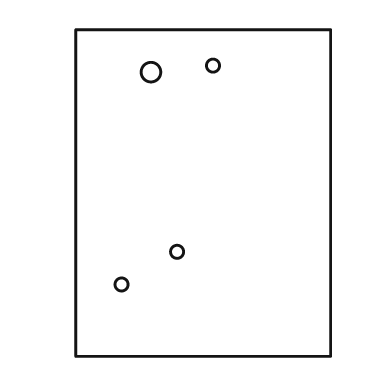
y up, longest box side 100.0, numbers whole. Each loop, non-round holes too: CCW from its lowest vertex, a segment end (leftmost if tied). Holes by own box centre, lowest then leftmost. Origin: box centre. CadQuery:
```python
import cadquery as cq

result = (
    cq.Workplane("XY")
    .moveTo(-39.0, -50.0)
    .lineTo(39.0, -50.0)
    .lineTo(39.0, 50.0)
    .lineTo(-39.0, 50.0)
    .close()
    .moveTo(-25.0, -28.0)
    .circle(2.0)
    .moveTo(-8.0, -18.0)
    .circle(2.0)
    .moveTo(-16.0, 37.0)
    .circle(3.0)
    .moveTo(3.0, 39.0)
    .circle(2.0)
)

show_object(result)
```